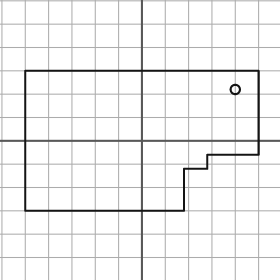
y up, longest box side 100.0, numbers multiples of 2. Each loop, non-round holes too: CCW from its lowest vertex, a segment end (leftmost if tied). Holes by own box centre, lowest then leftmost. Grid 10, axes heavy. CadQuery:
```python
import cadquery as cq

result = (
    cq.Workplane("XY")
    .moveTo(-50.0, -30.0)
    .lineTo(18.0, -30.0)
    .lineTo(18.0, -12.0)
    .lineTo(28.0, -12.0)
    .lineTo(28.0, -6.0)
    .lineTo(50.0, -6.0)
    .lineTo(50.0, 30.0)
    .lineTo(-50.0, 30.0)
    .close()
    .moveTo(40.0, 22.0)
    .circle(2.0)
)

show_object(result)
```